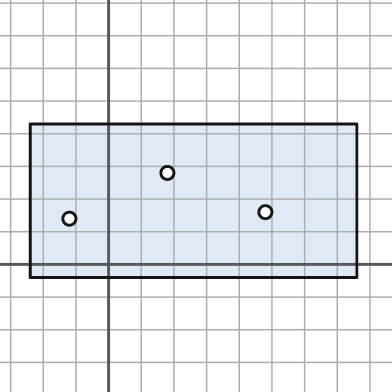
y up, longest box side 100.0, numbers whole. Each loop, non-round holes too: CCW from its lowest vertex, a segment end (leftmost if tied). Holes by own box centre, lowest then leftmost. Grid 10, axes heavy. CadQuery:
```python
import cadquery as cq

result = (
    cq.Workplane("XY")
    .moveTo(-24.0, -4.0)
    .lineTo(76.0, -4.0)
    .lineTo(76.0, 43.0)
    .lineTo(-24.0, 43.0)
    .close()
    .moveTo(-12.0, 14.0)
    .circle(2.0)
    .moveTo(48.0, 16.0)
    .circle(2.0)
    .moveTo(18.0, 28.0)
    .circle(2.0)
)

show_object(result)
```